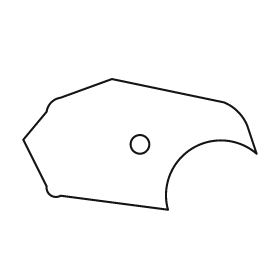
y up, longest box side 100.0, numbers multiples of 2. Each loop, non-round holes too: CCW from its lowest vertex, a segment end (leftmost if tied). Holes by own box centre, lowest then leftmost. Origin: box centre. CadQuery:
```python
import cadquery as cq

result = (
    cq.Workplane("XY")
    .moveTo(12.0, -28.0)
    .threePointArc((22.0, -2.0), (50.0, -4.0))
    .lineTo(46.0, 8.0)
    .threePointArc((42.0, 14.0), (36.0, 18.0))
    .lineTo(-12.0, 28.0)
    .lineTo(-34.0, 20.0)
    .threePointArc((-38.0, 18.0), (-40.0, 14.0))
    .lineTo(-50.0, 2.0)
    .lineTo(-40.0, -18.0)
    .threePointArc((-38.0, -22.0), (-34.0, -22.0))
    .close()
    .moveTo(0.0, 0.0)
    .circle(4.0)
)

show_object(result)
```